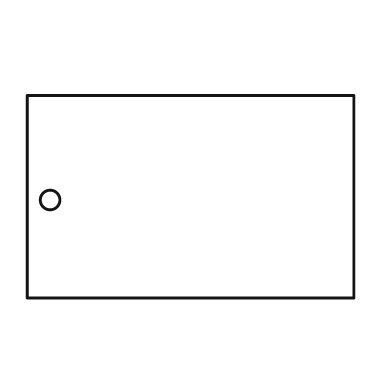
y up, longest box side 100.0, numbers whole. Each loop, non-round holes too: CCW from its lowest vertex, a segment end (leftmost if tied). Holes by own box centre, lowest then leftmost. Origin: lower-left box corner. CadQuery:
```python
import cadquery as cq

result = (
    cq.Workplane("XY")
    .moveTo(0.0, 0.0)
    .lineTo(100.0, 0.0)
    .lineTo(100.0, 62.0)
    .lineTo(0.0, 62.0)
    .close()
    .moveTo(7.0, 30.0)
    .circle(3.0)
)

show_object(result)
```